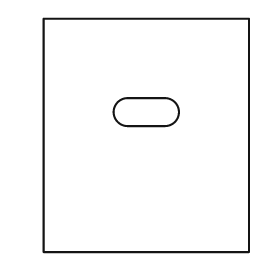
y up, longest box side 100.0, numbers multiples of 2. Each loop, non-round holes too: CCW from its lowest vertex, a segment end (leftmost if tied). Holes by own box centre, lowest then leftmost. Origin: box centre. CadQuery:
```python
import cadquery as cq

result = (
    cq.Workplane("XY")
    .moveTo(-44.0, -50.0)
    .lineTo(44.0, -50.0)
    .lineTo(44.0, 50.0)
    .lineTo(-44.0, 50.0)
    .close()
    .moveTo(-8.0, 4.0)
    .lineTo(8.0, 4.0)
    .threePointArc((14.0, 10.0), (8.0, 16.0))
    .lineTo(-8.0, 16.0)
    .threePointArc((-14.0, 10.0), (-8.0, 4.0))
    .close()
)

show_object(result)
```